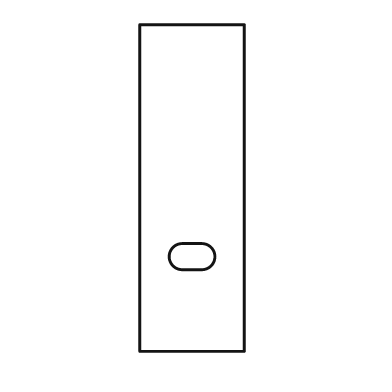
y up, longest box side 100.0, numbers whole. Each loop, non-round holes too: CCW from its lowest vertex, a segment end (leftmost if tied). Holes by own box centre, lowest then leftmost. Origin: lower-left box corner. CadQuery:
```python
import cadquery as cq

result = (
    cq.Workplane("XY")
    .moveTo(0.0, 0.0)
    .lineTo(32.0, 0.0)
    .lineTo(32.0, 100.0)
    .lineTo(0.0, 100.0)
    .close()
    .moveTo(13.0, 25.0)
    .lineTo(19.0, 25.0)
    .threePointArc((23.0, 29.0), (19.0, 33.0))
    .lineTo(13.0, 33.0)
    .threePointArc((9.0, 29.0), (13.0, 25.0))
    .close()
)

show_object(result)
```